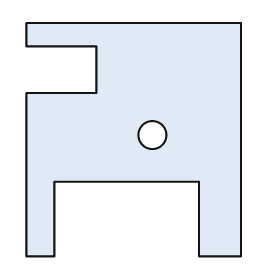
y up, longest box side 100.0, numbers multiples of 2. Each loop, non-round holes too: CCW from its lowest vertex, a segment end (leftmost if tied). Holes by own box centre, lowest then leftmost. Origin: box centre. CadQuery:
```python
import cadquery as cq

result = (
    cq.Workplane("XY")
    .moveTo(-46.0, -50.0)
    .lineTo(-34.0, -50.0)
    .lineTo(-34.0, -18.0)
    .lineTo(28.0, -18.0)
    .lineTo(28.0, -50.0)
    .lineTo(46.0, -50.0)
    .lineTo(46.0, 50.0)
    .lineTo(-46.0, 50.0)
    .lineTo(-46.0, 40.0)
    .lineTo(-16.0, 40.0)
    .lineTo(-16.0, 20.0)
    .lineTo(-46.0, 20.0)
    .close()
    .moveTo(8.0, 2.0)
    .circle(6.0)
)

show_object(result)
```